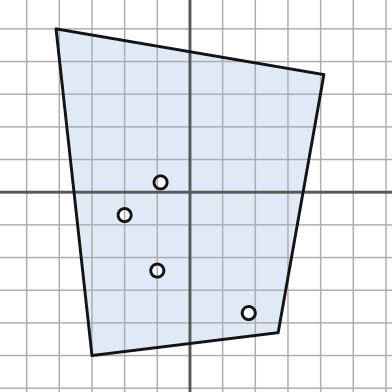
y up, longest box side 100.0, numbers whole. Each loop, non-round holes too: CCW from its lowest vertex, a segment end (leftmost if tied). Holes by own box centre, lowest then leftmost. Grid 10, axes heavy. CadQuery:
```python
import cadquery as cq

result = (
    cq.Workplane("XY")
    .moveTo(-30.0, -50.0)
    .lineTo(27.0, -43.0)
    .lineTo(41.0, 36.0)
    .lineTo(-41.0, 50.0)
    .close()
    .moveTo(18.0, -37.0)
    .circle(2.0)
    .moveTo(-10.0, -24.0)
    .circle(2.0)
    .moveTo(-20.0, -7.0)
    .circle(2.0)
    .moveTo(-9.0, 3.0)
    .circle(2.0)
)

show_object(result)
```